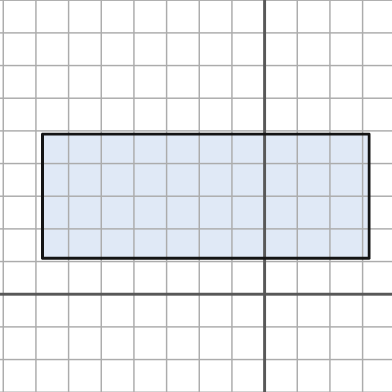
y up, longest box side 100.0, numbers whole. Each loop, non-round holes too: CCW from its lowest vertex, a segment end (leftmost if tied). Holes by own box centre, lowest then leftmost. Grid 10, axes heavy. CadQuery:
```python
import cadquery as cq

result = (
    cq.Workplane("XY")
    .moveTo(-68.0, 11.0)
    .lineTo(32.0, 11.0)
    .lineTo(32.0, 49.0)
    .lineTo(-68.0, 49.0)
    .close()
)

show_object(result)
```